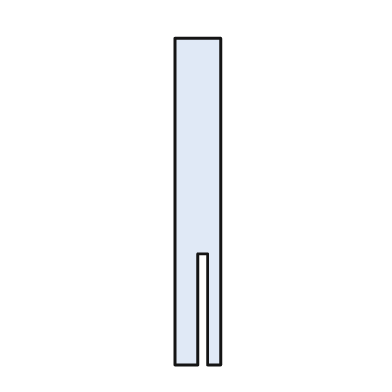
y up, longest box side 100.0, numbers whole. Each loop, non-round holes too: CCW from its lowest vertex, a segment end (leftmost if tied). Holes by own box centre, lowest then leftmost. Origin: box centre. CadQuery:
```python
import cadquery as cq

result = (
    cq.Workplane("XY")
    .moveTo(-7.0, -50.0)
    .lineTo(0.0, -50.0)
    .lineTo(0.0, -16.0)
    .lineTo(3.0, -16.0)
    .lineTo(3.0, -50.0)
    .lineTo(7.0, -50.0)
    .lineTo(7.0, 50.0)
    .lineTo(-7.0, 50.0)
    .close()
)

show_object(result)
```